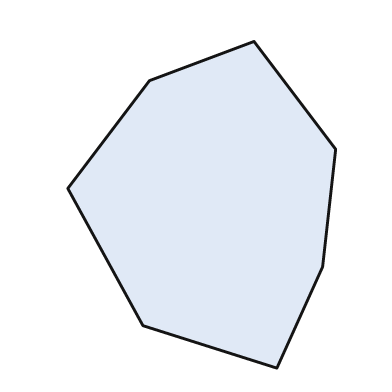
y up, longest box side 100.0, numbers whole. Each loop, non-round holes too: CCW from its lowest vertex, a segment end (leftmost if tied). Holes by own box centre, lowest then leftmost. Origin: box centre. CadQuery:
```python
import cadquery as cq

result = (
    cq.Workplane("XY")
    .moveTo(23.0, -50.0)
    .lineTo(37.0, -19.0)
    .lineTo(41.0, 17.0)
    .lineTo(16.0, 50.0)
    .lineTo(-16.0, 38.0)
    .lineTo(-41.0, 5.0)
    .lineTo(-18.0, -37.0)
    .close()
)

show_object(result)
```